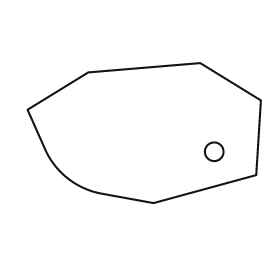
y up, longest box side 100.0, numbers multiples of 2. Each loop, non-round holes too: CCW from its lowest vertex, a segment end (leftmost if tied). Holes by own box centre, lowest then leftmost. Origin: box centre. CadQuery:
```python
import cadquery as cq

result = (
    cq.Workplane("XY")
    .moveTo(4.0, -30.0)
    .lineTo(48.0, -18.0)
    .lineTo(50.0, 14.0)
    .lineTo(24.0, 30.0)
    .lineTo(-24.0, 26.0)
    .lineTo(-50.0, 10.0)
    .lineTo(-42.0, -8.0)
    .threePointArc((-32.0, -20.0), (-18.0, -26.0))
    .close()
    .moveTo(30.0, -8.0)
    .circle(4.0)
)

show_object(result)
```